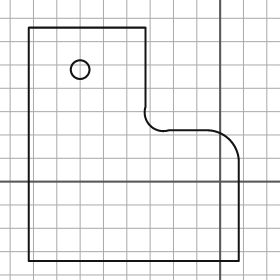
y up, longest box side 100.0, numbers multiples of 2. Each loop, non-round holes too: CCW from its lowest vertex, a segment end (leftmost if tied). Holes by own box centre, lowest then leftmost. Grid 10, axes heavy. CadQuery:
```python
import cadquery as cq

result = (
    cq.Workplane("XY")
    .moveTo(-82.0, -34.0)
    .lineTo(8.0, -34.0)
    .lineTo(8.0, 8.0)
    .threePointArc((4.0, 18.0), (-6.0, 22.0))
    .lineTo(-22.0, 22.0)
    .threePointArc((-30.0, 24.0), (-32.0, 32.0))
    .lineTo(-32.0, 66.0)
    .lineTo(-82.0, 66.0)
    .close()
    .moveTo(-60.0, 48.0)
    .circle(4.0)
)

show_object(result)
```